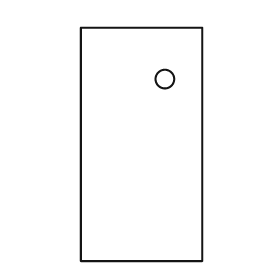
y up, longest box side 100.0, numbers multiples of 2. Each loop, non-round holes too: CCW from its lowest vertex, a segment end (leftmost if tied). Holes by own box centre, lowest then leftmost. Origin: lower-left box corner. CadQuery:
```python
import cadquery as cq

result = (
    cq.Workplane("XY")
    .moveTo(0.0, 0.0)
    .lineTo(52.0, 0.0)
    .lineTo(52.0, 100.0)
    .lineTo(0.0, 100.0)
    .close()
    .moveTo(36.0, 78.0)
    .circle(4.0)
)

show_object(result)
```